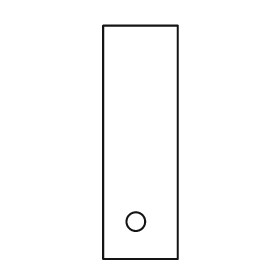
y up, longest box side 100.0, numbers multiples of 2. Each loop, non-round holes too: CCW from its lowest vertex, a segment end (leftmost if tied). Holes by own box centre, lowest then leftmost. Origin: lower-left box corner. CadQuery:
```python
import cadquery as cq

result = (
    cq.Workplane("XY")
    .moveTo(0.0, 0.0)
    .lineTo(32.0, 0.0)
    .lineTo(32.0, 100.0)
    .lineTo(0.0, 100.0)
    .close()
    .moveTo(14.0, 16.0)
    .circle(4.0)
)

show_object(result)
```